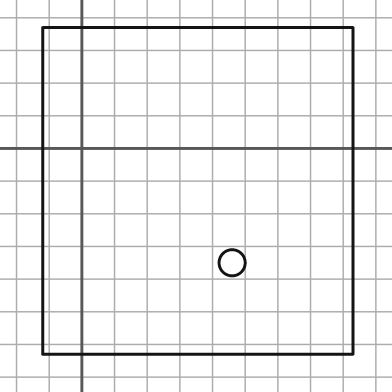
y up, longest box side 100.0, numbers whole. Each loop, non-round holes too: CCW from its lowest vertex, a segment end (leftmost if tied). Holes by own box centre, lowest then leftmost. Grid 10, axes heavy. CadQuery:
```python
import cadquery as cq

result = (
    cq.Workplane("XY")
    .moveTo(-12.0, -63.0)
    .lineTo(83.0, -63.0)
    .lineTo(83.0, 37.0)
    .lineTo(-12.0, 37.0)
    .close()
    .moveTo(46.0, -35.0)
    .circle(4.0)
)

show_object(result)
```